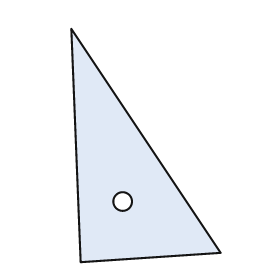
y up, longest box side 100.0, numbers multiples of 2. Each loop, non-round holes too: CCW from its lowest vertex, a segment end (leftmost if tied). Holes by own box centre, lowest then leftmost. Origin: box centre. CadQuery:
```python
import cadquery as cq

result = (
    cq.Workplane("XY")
    .moveTo(-28.0, -50.0)
    .lineTo(32.0, -46.0)
    .lineTo(-32.0, 50.0)
    .close()
    .moveTo(-10.0, -24.0)
    .circle(4.0)
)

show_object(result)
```